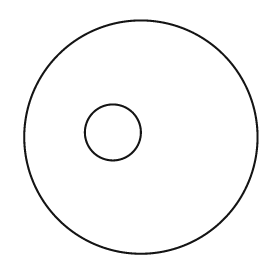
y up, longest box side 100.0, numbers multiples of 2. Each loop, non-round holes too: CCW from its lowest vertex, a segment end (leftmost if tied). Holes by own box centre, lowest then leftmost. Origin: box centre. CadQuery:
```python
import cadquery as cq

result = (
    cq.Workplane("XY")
    .moveTo(0.0, 0.0)
    .circle(50.0)
    .moveTo(-12.0, 2.0)
    .circle(12.0)
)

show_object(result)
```